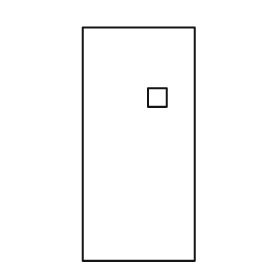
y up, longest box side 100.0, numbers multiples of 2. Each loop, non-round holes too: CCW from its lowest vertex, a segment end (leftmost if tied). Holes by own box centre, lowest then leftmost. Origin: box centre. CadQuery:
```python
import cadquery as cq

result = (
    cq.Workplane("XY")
    .moveTo(-24.0, -50.0)
    .lineTo(24.0, -50.0)
    .lineTo(24.0, 50.0)
    .lineTo(-24.0, 50.0)
    .close()
    .moveTo(4.0, 16.0)
    .lineTo(12.0, 16.0)
    .lineTo(12.0, 24.0)
    .lineTo(4.0, 24.0)
    .close()
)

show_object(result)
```